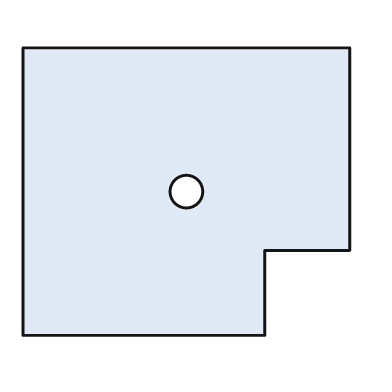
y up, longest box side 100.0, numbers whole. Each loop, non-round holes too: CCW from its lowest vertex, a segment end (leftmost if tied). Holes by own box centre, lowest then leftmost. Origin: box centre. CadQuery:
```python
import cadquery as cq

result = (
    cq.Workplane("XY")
    .moveTo(-50.0, -44.0)
    .lineTo(24.0, -44.0)
    .lineTo(24.0, -18.0)
    .lineTo(50.0, -18.0)
    .lineTo(50.0, 44.0)
    .lineTo(-50.0, 44.0)
    .close()
    .moveTo(0.0, 0.0)
    .circle(5.0)
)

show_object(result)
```